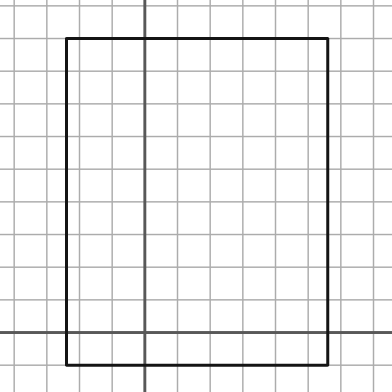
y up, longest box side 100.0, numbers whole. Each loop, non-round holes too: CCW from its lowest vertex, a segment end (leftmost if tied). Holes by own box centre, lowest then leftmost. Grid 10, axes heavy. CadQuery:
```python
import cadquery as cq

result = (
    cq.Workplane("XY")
    .moveTo(-24.0, -10.0)
    .lineTo(56.0, -10.0)
    .lineTo(56.0, 90.0)
    .lineTo(-24.0, 90.0)
    .close()
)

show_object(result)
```